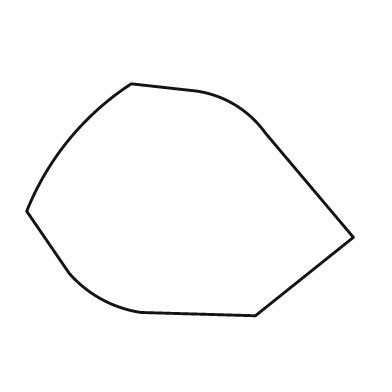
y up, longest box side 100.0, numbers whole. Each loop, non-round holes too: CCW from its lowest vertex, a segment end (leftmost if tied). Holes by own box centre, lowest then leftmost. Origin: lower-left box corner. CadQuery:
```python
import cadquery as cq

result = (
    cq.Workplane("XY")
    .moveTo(70.0, 0.0)
    .lineTo(100.0, 24.0)
    .lineTo(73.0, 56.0)
    .threePointArc((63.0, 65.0), (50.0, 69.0))
    .lineTo(32.0, 71.0)
    .threePointArc((13.0, 54.0), (0.0, 32.0))
    .lineTo(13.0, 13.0)
    .threePointArc((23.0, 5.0), (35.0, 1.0))
    .close()
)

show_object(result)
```